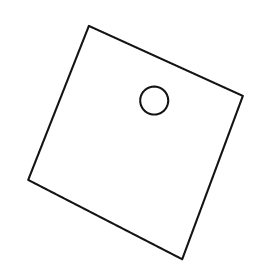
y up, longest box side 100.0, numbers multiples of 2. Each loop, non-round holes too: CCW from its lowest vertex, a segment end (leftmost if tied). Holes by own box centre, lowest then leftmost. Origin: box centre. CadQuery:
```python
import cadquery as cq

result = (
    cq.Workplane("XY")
    .moveTo(20.0, -50.0)
    .lineTo(46.0, 20.0)
    .lineTo(-20.0, 50.0)
    .lineTo(-46.0, -16.0)
    .close()
    .moveTo(8.0, 18.0)
    .circle(6.0)
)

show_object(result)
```